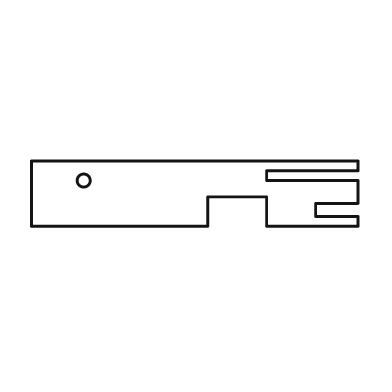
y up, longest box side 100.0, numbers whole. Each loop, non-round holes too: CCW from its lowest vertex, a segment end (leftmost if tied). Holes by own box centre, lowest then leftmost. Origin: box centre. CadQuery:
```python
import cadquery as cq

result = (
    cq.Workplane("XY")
    .moveTo(-50.0, -10.0)
    .lineTo(4.0, -10.0)
    .lineTo(4.0, -1.0)
    .lineTo(22.0, -1.0)
    .lineTo(22.0, -10.0)
    .lineTo(50.0, -10.0)
    .lineTo(50.0, -7.0)
    .lineTo(37.0, -7.0)
    .lineTo(37.0, -3.0)
    .lineTo(50.0, -3.0)
    .lineTo(50.0, 4.0)
    .lineTo(22.0, 4.0)
    .lineTo(22.0, 7.0)
    .lineTo(50.0, 7.0)
    .lineTo(50.0, 10.0)
    .lineTo(-50.0, 10.0)
    .close()
    .moveTo(-34.0, 4.0)
    .circle(2.0)
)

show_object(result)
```